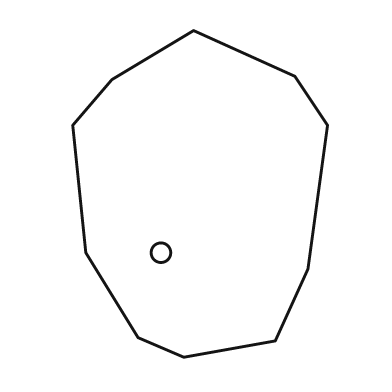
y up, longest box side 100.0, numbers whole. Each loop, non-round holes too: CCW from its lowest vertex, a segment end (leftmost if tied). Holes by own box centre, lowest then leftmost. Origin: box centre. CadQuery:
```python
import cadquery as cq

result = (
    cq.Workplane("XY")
    .moveTo(-5.0, -50.0)
    .lineTo(23.0, -45.0)
    .lineTo(33.0, -23.0)
    .lineTo(39.0, 21.0)
    .lineTo(29.0, 36.0)
    .lineTo(-2.0, 50.0)
    .lineTo(-27.0, 35.0)
    .lineTo(-39.0, 21.0)
    .lineTo(-35.0, -18.0)
    .lineTo(-19.0, -44.0)
    .close()
    .moveTo(-12.0, -18.0)
    .circle(3.0)
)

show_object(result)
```